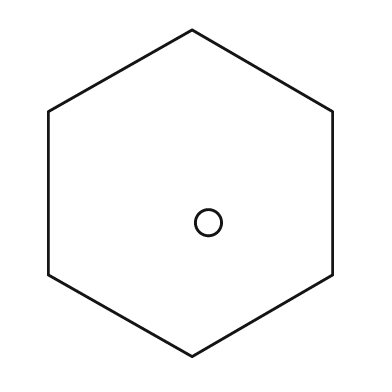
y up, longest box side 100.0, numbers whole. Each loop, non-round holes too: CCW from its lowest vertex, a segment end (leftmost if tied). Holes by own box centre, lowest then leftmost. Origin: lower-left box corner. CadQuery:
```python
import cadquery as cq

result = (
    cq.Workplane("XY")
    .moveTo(44.0, 0.0)
    .lineTo(87.0, 25.0)
    .lineTo(87.0, 75.0)
    .lineTo(44.0, 100.0)
    .lineTo(0.0, 75.0)
    .lineTo(0.0, 25.0)
    .close()
    .moveTo(49.0, 41.0)
    .circle(4.0)
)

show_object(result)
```